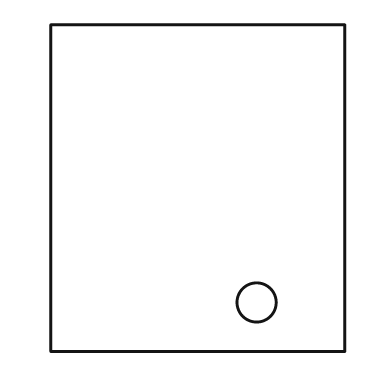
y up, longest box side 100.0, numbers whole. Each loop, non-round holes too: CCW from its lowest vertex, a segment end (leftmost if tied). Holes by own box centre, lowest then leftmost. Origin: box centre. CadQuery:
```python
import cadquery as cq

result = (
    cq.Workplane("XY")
    .moveTo(-45.0, -50.0)
    .lineTo(45.0, -50.0)
    .lineTo(45.0, 50.0)
    .lineTo(-45.0, 50.0)
    .close()
    .moveTo(18.0, -35.0)
    .circle(6.0)
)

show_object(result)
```